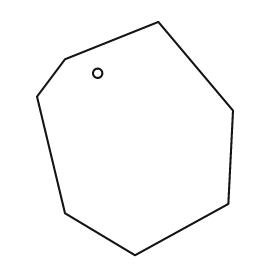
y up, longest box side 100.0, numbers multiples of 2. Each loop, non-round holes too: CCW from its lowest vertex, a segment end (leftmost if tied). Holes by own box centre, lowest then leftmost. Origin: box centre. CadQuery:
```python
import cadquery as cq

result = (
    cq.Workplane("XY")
    .moveTo(0.0, -50.0)
    .lineTo(40.0, -28.0)
    .lineTo(42.0, 12.0)
    .lineTo(10.0, 50.0)
    .lineTo(-30.0, 34.0)
    .lineTo(-42.0, 18.0)
    .lineTo(-30.0, -32.0)
    .close()
    .moveTo(-16.0, 28.0)
    .circle(2.0)
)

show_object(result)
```